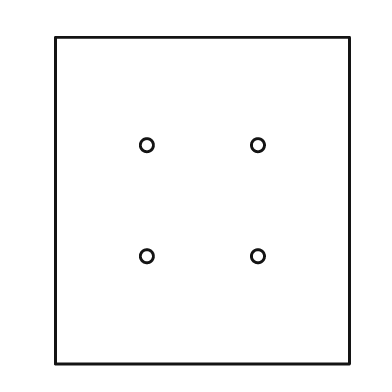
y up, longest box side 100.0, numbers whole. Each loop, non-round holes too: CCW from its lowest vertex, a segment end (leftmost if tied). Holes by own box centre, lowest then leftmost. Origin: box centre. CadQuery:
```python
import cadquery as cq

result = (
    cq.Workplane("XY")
    .moveTo(-45.0, -50.0)
    .lineTo(45.0, -50.0)
    .lineTo(45.0, 50.0)
    .lineTo(-45.0, 50.0)
    .close()
    .moveTo(-17.0, -17.0)
    .circle(2.0)
    .moveTo(17.0, -17.0)
    .circle(2.0)
    .moveTo(-17.0, 17.0)
    .circle(2.0)
    .moveTo(17.0, 17.0)
    .circle(2.0)
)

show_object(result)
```